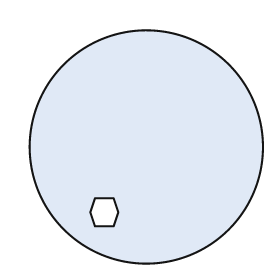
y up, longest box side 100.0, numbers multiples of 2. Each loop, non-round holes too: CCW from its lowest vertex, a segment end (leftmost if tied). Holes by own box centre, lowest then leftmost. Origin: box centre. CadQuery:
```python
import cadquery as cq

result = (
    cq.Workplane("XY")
    .moveTo(0.0, 0.0)
    .circle(50.0)
    .moveTo(-22.0, -34.0)
    .lineTo(-14.0, -34.0)
    .lineTo(-12.0, -28.0)
    .lineTo(-14.0, -22.0)
    .lineTo(-22.0, -22.0)
    .lineTo(-24.0, -28.0)
    .close()
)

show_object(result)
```